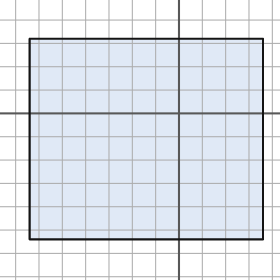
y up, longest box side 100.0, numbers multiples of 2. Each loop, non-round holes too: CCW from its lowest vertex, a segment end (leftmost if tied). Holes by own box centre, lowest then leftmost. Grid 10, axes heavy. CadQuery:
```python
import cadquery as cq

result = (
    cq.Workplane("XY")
    .moveTo(-64.0, -54.0)
    .lineTo(36.0, -54.0)
    .lineTo(36.0, 32.0)
    .lineTo(-64.0, 32.0)
    .close()
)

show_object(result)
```